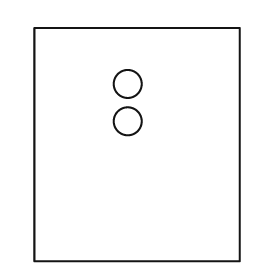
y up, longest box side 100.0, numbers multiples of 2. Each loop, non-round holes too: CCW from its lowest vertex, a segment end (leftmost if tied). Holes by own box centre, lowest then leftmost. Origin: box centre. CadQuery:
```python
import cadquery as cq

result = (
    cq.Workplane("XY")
    .moveTo(-44.0, -50.0)
    .lineTo(44.0, -50.0)
    .lineTo(44.0, 50.0)
    .lineTo(-44.0, 50.0)
    .close()
    .moveTo(-4.0, 10.0)
    .circle(6.0)
    .moveTo(-4.0, 26.0)
    .circle(6.0)
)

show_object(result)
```